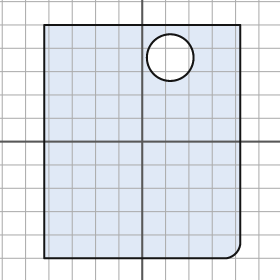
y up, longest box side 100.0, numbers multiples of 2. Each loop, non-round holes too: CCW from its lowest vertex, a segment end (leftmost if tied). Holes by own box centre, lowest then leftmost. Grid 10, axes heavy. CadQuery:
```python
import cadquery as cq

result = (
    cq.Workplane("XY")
    .moveTo(-42.0, -50.0)
    .lineTo(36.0, -50.0)
    .threePointArc((40.0, -48.0), (42.0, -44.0))
    .lineTo(42.0, 50.0)
    .lineTo(-42.0, 50.0)
    .close()
    .moveTo(12.0, 36.0)
    .circle(10.0)
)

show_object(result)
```